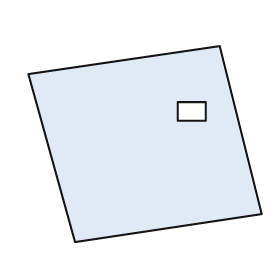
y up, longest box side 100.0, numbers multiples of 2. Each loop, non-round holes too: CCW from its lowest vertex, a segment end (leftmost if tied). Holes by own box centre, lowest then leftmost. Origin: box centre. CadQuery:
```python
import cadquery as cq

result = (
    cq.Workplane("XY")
    .moveTo(-30.0, -42.0)
    .lineTo(50.0, -30.0)
    .lineTo(32.0, 42.0)
    .lineTo(-50.0, 30.0)
    .close()
    .moveTo(14.0, 10.0)
    .lineTo(26.0, 10.0)
    .lineTo(26.0, 18.0)
    .lineTo(14.0, 18.0)
    .close()
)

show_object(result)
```